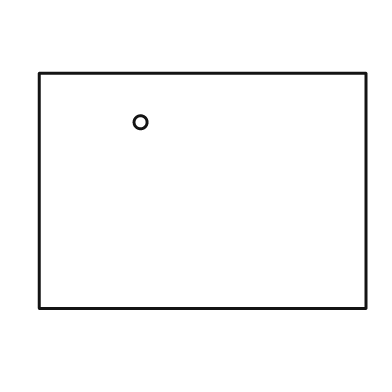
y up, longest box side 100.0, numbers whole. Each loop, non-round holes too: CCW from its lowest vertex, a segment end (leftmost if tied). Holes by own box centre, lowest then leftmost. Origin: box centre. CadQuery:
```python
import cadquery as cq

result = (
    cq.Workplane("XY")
    .moveTo(-50.0, -36.0)
    .lineTo(50.0, -36.0)
    .lineTo(50.0, 36.0)
    .lineTo(-50.0, 36.0)
    .close()
    .moveTo(-19.0, 21.0)
    .circle(2.0)
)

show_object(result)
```